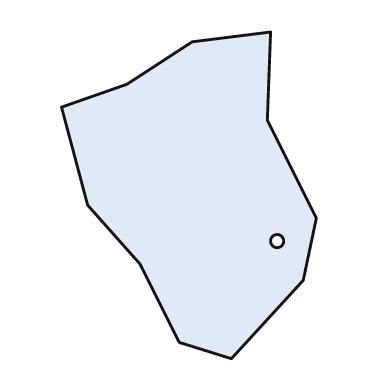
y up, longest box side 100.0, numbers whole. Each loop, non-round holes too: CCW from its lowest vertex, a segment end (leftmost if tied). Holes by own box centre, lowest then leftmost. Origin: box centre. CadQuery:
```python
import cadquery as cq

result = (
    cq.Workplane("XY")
    .moveTo(13.0, -50.0)
    .lineTo(35.0, -26.0)
    .lineTo(39.0, -7.0)
    .lineTo(24.0, 23.0)
    .lineTo(25.0, 50.0)
    .lineTo(1.0, 47.0)
    .lineTo(-19.0, 34.0)
    .lineTo(-39.0, 27.0)
    .lineTo(-31.0, -3.0)
    .lineTo(-15.0, -21.0)
    .lineTo(-3.0, -45.0)
    .close()
    .moveTo(27.0, -14.0)
    .circle(2.0)
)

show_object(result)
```